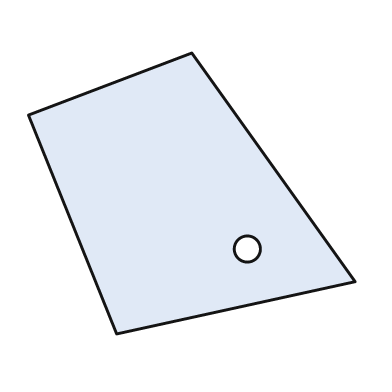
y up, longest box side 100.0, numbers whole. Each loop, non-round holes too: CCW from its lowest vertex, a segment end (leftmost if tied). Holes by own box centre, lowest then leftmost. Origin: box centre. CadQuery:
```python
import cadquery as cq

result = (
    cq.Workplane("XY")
    .moveTo(-23.0, -43.0)
    .lineTo(50.0, -27.0)
    .lineTo(0.0, 43.0)
    .lineTo(-50.0, 24.0)
    .close()
    .moveTo(17.0, -17.0)
    .circle(4.0)
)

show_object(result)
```